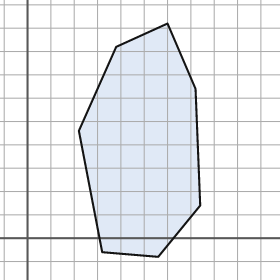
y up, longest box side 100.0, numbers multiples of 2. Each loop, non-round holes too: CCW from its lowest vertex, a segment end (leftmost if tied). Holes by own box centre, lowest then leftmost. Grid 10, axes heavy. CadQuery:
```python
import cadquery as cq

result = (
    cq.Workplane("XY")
    .moveTo(56.0, -8.0)
    .lineTo(74.0, 14.0)
    .lineTo(72.0, 64.0)
    .lineTo(60.0, 92.0)
    .lineTo(38.0, 82.0)
    .lineTo(22.0, 46.0)
    .lineTo(32.0, -6.0)
    .close()
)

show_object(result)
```